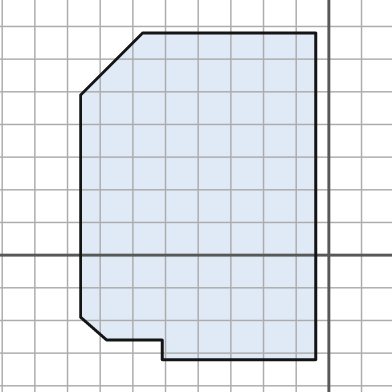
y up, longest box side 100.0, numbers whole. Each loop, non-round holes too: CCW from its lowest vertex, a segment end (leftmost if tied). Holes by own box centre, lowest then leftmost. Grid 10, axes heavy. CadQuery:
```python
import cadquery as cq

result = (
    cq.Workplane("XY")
    .moveTo(-51.0, -32.0)
    .lineTo(-4.0, -32.0)
    .lineTo(-4.0, 68.0)
    .lineTo(-57.0, 68.0)
    .lineTo(-76.0, 49.0)
    .lineTo(-76.0, -19.0)
    .lineTo(-68.0, -26.0)
    .lineTo(-51.0, -26.0)
    .close()
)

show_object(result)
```